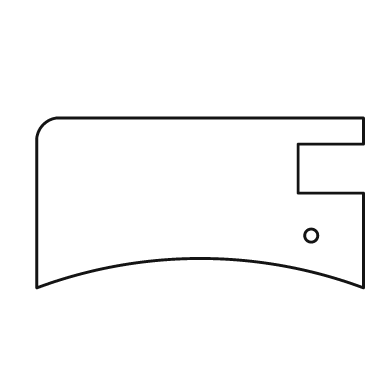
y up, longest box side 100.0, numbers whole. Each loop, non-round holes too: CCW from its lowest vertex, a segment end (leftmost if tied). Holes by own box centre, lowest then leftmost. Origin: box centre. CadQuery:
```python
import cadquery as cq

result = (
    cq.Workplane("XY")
    .moveTo(-50.0, -26.0)
    .threePointArc((0.0, -17.0), (50.0, -26.0))
    .lineTo(50.0, 3.0)
    .lineTo(30.0, 3.0)
    .lineTo(30.0, 18.0)
    .lineTo(50.0, 18.0)
    .lineTo(50.0, 26.0)
    .lineTo(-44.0, 26.0)
    .threePointArc((-48.0, 24.0), (-50.0, 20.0))
    .close()
    .moveTo(34.0, -10.0)
    .circle(2.0)
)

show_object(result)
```